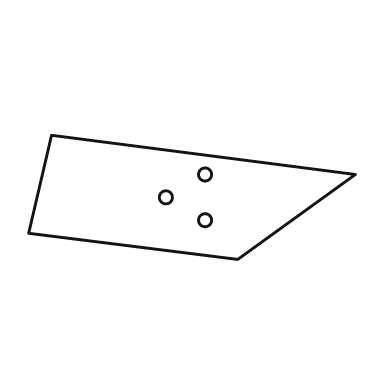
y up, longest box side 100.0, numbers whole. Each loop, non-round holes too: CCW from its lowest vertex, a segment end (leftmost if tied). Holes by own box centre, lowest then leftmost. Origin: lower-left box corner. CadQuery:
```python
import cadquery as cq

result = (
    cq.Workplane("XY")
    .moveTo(64.0, 0.0)
    .lineTo(100.0, 26.0)
    .lineTo(7.0, 38.0)
    .lineTo(0.0, 8.0)
    .close()
    .moveTo(54.0, 12.0)
    .circle(2.0)
    .moveTo(42.0, 19.0)
    .circle(2.0)
    .moveTo(54.0, 26.0)
    .circle(2.0)
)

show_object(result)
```